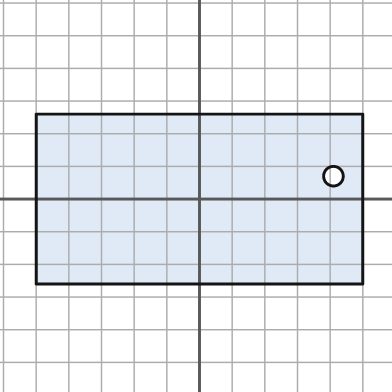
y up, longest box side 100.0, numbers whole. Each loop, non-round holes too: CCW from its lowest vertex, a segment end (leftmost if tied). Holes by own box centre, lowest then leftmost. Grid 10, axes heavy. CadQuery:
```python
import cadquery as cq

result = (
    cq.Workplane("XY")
    .moveTo(-50.0, -26.0)
    .lineTo(50.0, -26.0)
    .lineTo(50.0, 26.0)
    .lineTo(-50.0, 26.0)
    .close()
    .moveTo(41.0, 7.0)
    .circle(3.0)
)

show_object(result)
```